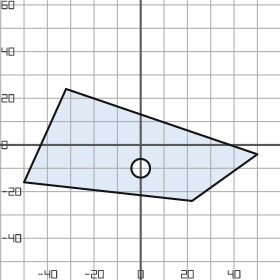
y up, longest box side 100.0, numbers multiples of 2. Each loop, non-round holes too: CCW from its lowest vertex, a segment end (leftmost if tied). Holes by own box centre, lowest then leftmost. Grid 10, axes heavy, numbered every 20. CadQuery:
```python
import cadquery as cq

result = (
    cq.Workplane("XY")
    .moveTo(22.0, -24.0)
    .lineTo(50.0, -4.0)
    .lineTo(-32.0, 24.0)
    .lineTo(-50.0, -16.0)
    .close()
    .moveTo(0.0, -10.0)
    .circle(4.0)
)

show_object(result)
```